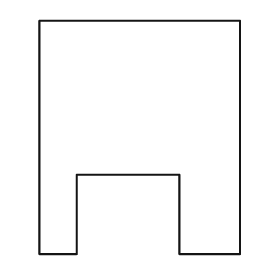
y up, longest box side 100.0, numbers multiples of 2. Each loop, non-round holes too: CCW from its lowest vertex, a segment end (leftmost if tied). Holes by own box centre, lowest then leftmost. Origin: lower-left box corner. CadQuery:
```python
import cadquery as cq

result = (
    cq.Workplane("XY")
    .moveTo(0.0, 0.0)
    .lineTo(16.0, 0.0)
    .lineTo(16.0, 34.0)
    .lineTo(60.0, 34.0)
    .lineTo(60.0, 0.0)
    .lineTo(86.0, 0.0)
    .lineTo(86.0, 100.0)
    .lineTo(0.0, 100.0)
    .close()
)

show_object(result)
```